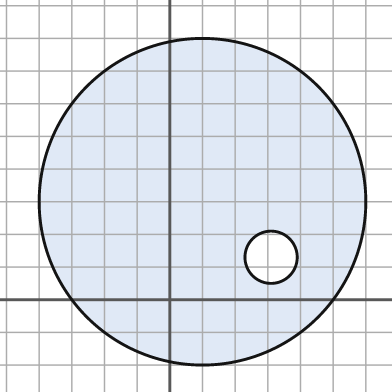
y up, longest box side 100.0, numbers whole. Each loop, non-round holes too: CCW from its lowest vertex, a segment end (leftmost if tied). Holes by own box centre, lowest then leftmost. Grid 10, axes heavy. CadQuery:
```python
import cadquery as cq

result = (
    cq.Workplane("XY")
    .moveTo(10.0, 30.0)
    .circle(50.0)
    .moveTo(31.0, 13.0)
    .circle(8.0)
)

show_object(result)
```